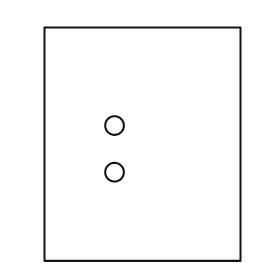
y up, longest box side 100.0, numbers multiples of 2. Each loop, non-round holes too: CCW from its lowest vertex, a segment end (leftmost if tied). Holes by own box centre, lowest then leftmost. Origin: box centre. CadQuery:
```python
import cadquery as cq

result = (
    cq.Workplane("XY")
    .moveTo(-42.0, -50.0)
    .lineTo(42.0, -50.0)
    .lineTo(42.0, 50.0)
    .lineTo(-42.0, 50.0)
    .close()
    .moveTo(-12.0, -12.0)
    .circle(4.0)
    .moveTo(-12.0, 8.0)
    .circle(4.0)
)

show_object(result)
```